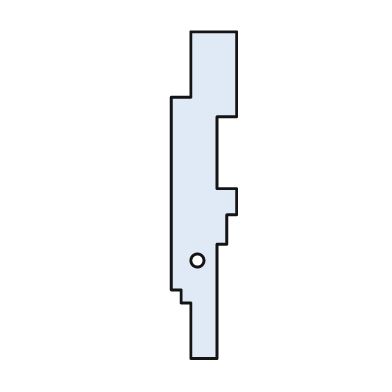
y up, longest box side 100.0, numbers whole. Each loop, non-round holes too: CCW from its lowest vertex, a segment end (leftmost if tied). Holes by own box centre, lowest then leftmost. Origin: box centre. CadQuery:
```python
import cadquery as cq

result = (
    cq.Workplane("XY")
    .moveTo(-4.0, -50.0)
    .lineTo(4.0, -50.0)
    .lineTo(4.0, -15.0)
    .lineTo(7.0, -15.0)
    .lineTo(7.0, -6.0)
    .lineTo(10.0, -6.0)
    .lineTo(10.0, 2.0)
    .lineTo(4.0, 2.0)
    .lineTo(4.0, 24.0)
    .lineTo(10.0, 24.0)
    .lineTo(10.0, 50.0)
    .lineTo(-4.0, 50.0)
    .lineTo(-4.0, 30.0)
    .lineTo(-10.0, 30.0)
    .lineTo(-10.0, -29.0)
    .lineTo(-7.0, -29.0)
    .lineTo(-7.0, -33.0)
    .lineTo(-4.0, -33.0)
    .close()
    .moveTo(-2.0, -20.0)
    .circle(2.0)
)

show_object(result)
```